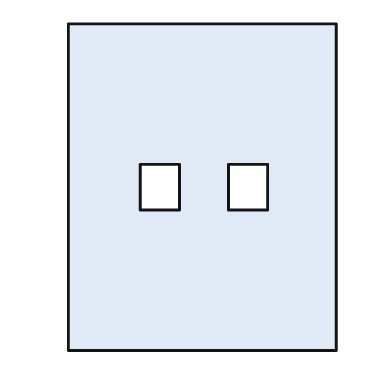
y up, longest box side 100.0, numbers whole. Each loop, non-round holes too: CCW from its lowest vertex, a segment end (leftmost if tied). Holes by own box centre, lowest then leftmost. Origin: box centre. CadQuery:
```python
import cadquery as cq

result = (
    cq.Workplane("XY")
    .moveTo(-41.0, -50.0)
    .lineTo(41.0, -50.0)
    .lineTo(41.0, 50.0)
    .lineTo(-41.0, 50.0)
    .close()
    .moveTo(-19.0, -7.0)
    .lineTo(-7.0, -7.0)
    .lineTo(-7.0, 7.0)
    .lineTo(-19.0, 7.0)
    .close()
    .moveTo(8.0, -7.0)
    .lineTo(20.0, -7.0)
    .lineTo(20.0, 7.0)
    .lineTo(8.0, 7.0)
    .close()
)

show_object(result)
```